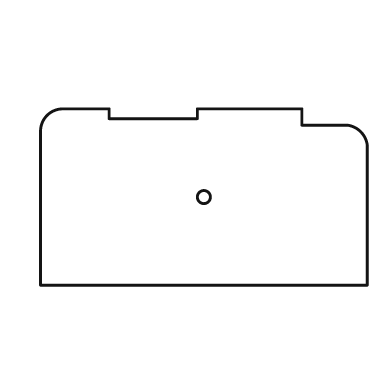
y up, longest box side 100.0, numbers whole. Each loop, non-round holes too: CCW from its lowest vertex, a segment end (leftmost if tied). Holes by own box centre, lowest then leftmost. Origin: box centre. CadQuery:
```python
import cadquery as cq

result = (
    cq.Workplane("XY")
    .moveTo(-50.0, -27.0)
    .lineTo(50.0, -27.0)
    .lineTo(50.0, 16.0)
    .threePointArc((48.0, 20.0), (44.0, 22.0))
    .lineTo(30.0, 22.0)
    .lineTo(30.0, 27.0)
    .lineTo(-2.0, 27.0)
    .lineTo(-2.0, 24.0)
    .lineTo(-29.0, 24.0)
    .lineTo(-29.0, 27.0)
    .lineTo(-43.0, 27.0)
    .threePointArc((-48.0, 25.0), (-50.0, 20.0))
    .close()
    .moveTo(0.0, 0.0)
    .circle(2.0)
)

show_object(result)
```